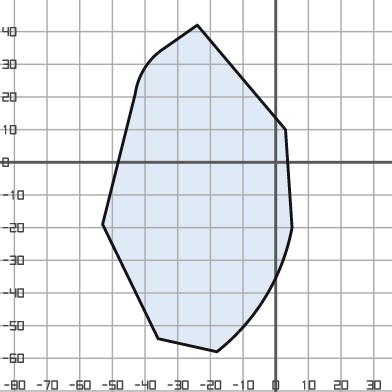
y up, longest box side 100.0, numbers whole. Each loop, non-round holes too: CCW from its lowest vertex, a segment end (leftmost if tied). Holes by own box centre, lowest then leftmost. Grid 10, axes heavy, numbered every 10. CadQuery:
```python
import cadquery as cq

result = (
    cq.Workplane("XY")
    .moveTo(-18.0, -58.0)
    .threePointArc((-3.0, -41.0), (5.0, -20.0))
    .lineTo(3.0, 10.0)
    .lineTo(-24.0, 42.0)
    .lineTo(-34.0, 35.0)
    .threePointArc((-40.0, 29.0), (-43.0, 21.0))
    .lineTo(-53.0, -19.0)
    .lineTo(-36.0, -54.0)
    .close()
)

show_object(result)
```